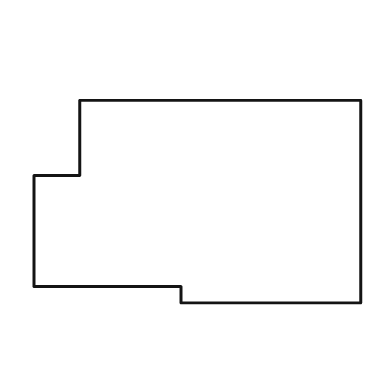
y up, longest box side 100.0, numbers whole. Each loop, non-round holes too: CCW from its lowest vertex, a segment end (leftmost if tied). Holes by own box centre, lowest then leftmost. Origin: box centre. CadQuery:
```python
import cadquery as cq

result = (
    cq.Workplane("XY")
    .moveTo(-5.0, -31.0)
    .lineTo(50.0, -31.0)
    .lineTo(50.0, 31.0)
    .lineTo(-36.0, 31.0)
    .lineTo(-36.0, 8.0)
    .lineTo(-50.0, 8.0)
    .lineTo(-50.0, -26.0)
    .lineTo(-5.0, -26.0)
    .close()
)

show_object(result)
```